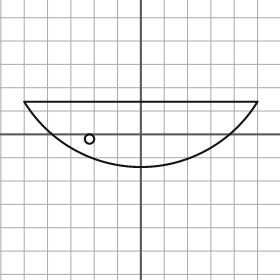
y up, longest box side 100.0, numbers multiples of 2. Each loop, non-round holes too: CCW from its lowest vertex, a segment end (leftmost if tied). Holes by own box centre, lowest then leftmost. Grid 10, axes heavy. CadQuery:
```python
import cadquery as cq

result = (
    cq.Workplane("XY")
    .moveTo(-50.0, 14.0)
    .threePointArc((0.0, -14.0), (50.0, 14.0))
    .close()
    .moveTo(-22.0, -2.0)
    .circle(2.0)
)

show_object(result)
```